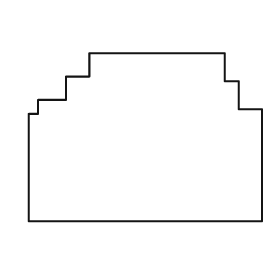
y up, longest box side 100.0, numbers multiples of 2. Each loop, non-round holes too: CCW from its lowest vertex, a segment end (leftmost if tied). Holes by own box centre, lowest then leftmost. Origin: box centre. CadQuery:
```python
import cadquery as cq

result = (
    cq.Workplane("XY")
    .moveTo(-50.0, -36.0)
    .lineTo(50.0, -36.0)
    .lineTo(50.0, 12.0)
    .lineTo(40.0, 12.0)
    .lineTo(40.0, 24.0)
    .lineTo(34.0, 24.0)
    .lineTo(34.0, 36.0)
    .lineTo(-24.0, 36.0)
    .lineTo(-24.0, 26.0)
    .lineTo(-34.0, 26.0)
    .lineTo(-34.0, 16.0)
    .lineTo(-46.0, 16.0)
    .lineTo(-46.0, 10.0)
    .lineTo(-50.0, 10.0)
    .close()
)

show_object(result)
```